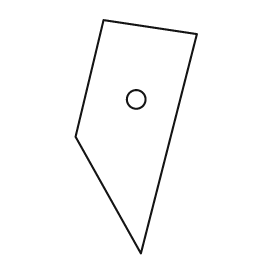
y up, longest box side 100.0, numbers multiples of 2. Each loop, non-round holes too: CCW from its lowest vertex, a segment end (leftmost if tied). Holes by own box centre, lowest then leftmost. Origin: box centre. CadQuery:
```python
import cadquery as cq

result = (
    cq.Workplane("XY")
    .moveTo(2.0, -50.0)
    .lineTo(26.0, 44.0)
    .lineTo(-14.0, 50.0)
    .lineTo(-26.0, 0.0)
    .close()
    .moveTo(0.0, 16.0)
    .circle(4.0)
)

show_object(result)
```